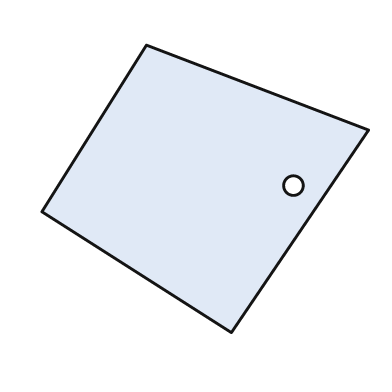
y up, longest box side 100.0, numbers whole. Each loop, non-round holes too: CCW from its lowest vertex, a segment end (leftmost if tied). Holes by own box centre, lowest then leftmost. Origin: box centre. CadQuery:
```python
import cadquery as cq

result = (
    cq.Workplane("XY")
    .moveTo(8.0, -44.0)
    .lineTo(50.0, 18.0)
    .lineTo(-18.0, 44.0)
    .lineTo(-50.0, -7.0)
    .close()
    .moveTo(27.0, 1.0)
    .circle(3.0)
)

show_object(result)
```